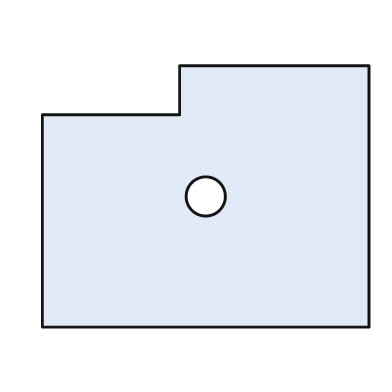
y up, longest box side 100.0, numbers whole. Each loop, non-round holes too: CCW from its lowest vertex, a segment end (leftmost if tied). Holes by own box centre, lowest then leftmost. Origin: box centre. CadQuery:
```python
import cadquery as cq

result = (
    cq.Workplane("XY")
    .moveTo(-50.0, -40.0)
    .lineTo(50.0, -40.0)
    .lineTo(50.0, 40.0)
    .lineTo(-8.0, 40.0)
    .lineTo(-8.0, 25.0)
    .lineTo(-50.0, 25.0)
    .close()
    .moveTo(0.0, 0.0)
    .circle(6.0)
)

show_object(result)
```